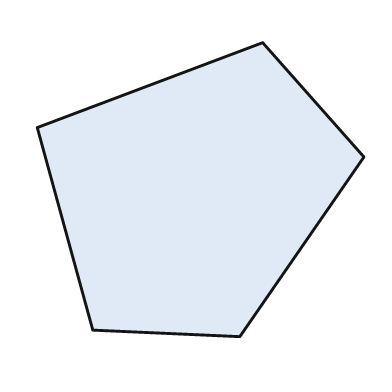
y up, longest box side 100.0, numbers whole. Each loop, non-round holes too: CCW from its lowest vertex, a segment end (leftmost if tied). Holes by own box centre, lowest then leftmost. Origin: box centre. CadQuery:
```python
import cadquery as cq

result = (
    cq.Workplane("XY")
    .moveTo(12.0, -45.0)
    .lineTo(50.0, 10.0)
    .lineTo(19.0, 45.0)
    .lineTo(-50.0, 19.0)
    .lineTo(-33.0, -43.0)
    .close()
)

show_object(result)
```